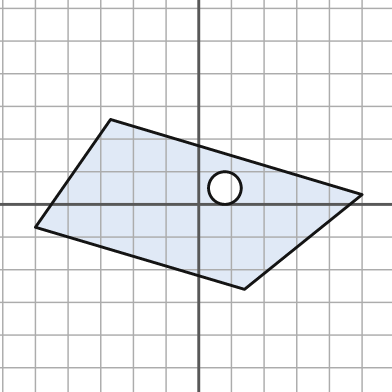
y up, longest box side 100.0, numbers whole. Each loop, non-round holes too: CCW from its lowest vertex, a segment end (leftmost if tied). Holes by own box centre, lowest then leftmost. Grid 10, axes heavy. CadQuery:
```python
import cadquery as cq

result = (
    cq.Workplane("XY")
    .moveTo(14.0, -26.0)
    .lineTo(50.0, 3.0)
    .lineTo(-27.0, 26.0)
    .lineTo(-50.0, -7.0)
    .close()
    .moveTo(8.0, 5.0)
    .circle(5.0)
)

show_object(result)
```